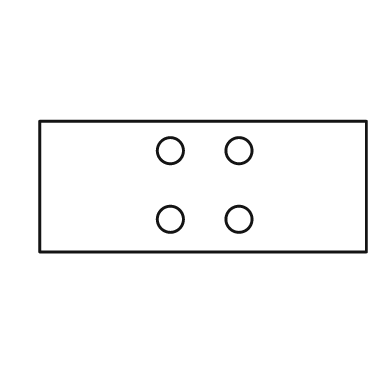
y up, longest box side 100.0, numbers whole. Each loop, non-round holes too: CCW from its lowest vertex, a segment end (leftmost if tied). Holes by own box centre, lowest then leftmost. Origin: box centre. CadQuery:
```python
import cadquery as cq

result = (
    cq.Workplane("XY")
    .moveTo(-50.0, -20.0)
    .lineTo(50.0, -20.0)
    .lineTo(50.0, 20.0)
    .lineTo(-50.0, 20.0)
    .close()
    .moveTo(-10.0, -10.0)
    .circle(4.0)
    .moveTo(11.0, -10.0)
    .circle(4.0)
    .moveTo(-10.0, 11.0)
    .circle(4.0)
    .moveTo(11.0, 11.0)
    .circle(4.0)
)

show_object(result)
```